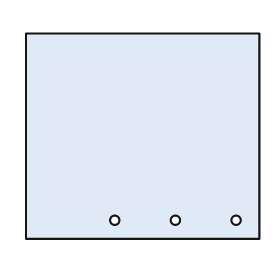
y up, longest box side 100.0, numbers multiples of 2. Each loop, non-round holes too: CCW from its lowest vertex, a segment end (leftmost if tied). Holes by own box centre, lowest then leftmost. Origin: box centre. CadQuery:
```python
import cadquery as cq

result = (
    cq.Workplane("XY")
    .moveTo(-50.0, -44.0)
    .lineTo(50.0, -44.0)
    .lineTo(50.0, 44.0)
    .lineTo(-50.0, 44.0)
    .close()
    .moveTo(-12.0, -36.0)
    .circle(2.0)
    .moveTo(14.0, -36.0)
    .circle(2.0)
    .moveTo(40.0, -36.0)
    .circle(2.0)
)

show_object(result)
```